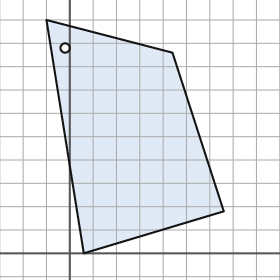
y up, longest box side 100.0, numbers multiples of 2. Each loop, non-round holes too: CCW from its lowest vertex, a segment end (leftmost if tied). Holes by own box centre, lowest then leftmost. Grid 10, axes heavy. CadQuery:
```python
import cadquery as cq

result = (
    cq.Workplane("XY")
    .moveTo(6.0, 0.0)
    .lineTo(66.0, 18.0)
    .lineTo(44.0, 86.0)
    .lineTo(-10.0, 100.0)
    .close()
    .moveTo(-2.0, 88.0)
    .circle(2.0)
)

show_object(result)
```